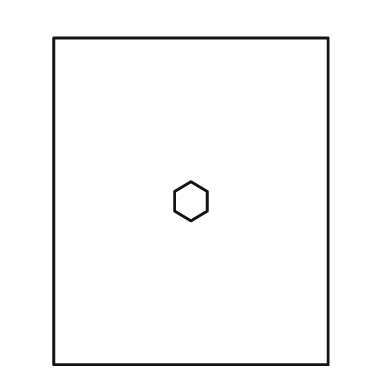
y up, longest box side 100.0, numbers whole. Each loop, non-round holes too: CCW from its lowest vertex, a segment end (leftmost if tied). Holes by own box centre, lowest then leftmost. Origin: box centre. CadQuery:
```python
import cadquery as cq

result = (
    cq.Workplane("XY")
    .moveTo(-42.0, -50.0)
    .lineTo(42.0, -50.0)
    .lineTo(42.0, 50.0)
    .lineTo(-42.0, 50.0)
    .close()
    .moveTo(0.0, -6.0)
    .lineTo(5.0, -3.0)
    .lineTo(5.0, 3.0)
    .lineTo(0.0, 6.0)
    .lineTo(-5.0, 3.0)
    .lineTo(-5.0, -3.0)
    .close()
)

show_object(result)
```